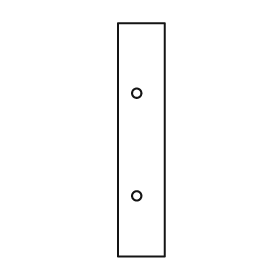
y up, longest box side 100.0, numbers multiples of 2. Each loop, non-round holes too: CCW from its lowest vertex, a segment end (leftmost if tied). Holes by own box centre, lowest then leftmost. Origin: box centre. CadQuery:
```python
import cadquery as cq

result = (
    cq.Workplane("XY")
    .moveTo(-10.0, -50.0)
    .lineTo(10.0, -50.0)
    .lineTo(10.0, 50.0)
    .lineTo(-10.0, 50.0)
    .close()
    .moveTo(-2.0, -24.0)
    .circle(2.0)
    .moveTo(-2.0, 20.0)
    .circle(2.0)
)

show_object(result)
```